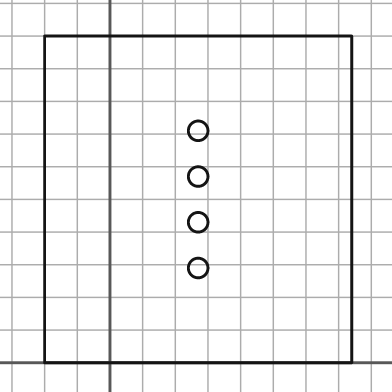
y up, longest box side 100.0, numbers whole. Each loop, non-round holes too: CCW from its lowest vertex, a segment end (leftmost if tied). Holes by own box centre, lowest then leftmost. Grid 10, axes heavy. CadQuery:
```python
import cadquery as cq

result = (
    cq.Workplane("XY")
    .moveTo(-20.0, 0.0)
    .lineTo(74.0, 0.0)
    .lineTo(74.0, 100.0)
    .lineTo(-20.0, 100.0)
    .close()
    .moveTo(27.0, 29.0)
    .circle(3.0)
    .moveTo(27.0, 43.0)
    .circle(3.0)
    .moveTo(27.0, 57.0)
    .circle(3.0)
    .moveTo(27.0, 71.0)
    .circle(3.0)
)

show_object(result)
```